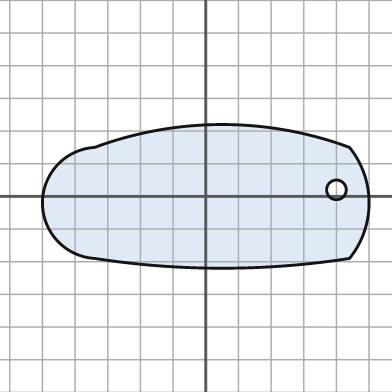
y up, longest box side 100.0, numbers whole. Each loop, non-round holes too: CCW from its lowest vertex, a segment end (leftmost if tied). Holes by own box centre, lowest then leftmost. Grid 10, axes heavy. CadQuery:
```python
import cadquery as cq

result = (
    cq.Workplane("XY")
    .moveTo(-34.0, -19.0)
    .threePointArc((5.0, -22.0), (44.0, -19.0))
    .threePointArc((50.0, -2.0), (44.0, 15.0))
    .threePointArc((5.0, 22.0), (-34.0, 15.0))
    .threePointArc((-50.0, -2.0), (-34.0, -19.0))
    .close()
    .moveTo(40.0, 2.0)
    .circle(3.0)
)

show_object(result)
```